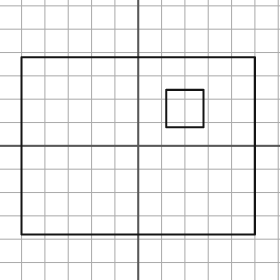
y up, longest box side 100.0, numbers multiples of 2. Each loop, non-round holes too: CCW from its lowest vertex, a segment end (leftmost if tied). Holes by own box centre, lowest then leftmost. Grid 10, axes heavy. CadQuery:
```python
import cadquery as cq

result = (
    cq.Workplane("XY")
    .moveTo(-50.0, -38.0)
    .lineTo(50.0, -38.0)
    .lineTo(50.0, 38.0)
    .lineTo(-50.0, 38.0)
    .close()
    .moveTo(12.0, 8.0)
    .lineTo(28.0, 8.0)
    .lineTo(28.0, 24.0)
    .lineTo(12.0, 24.0)
    .close()
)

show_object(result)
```